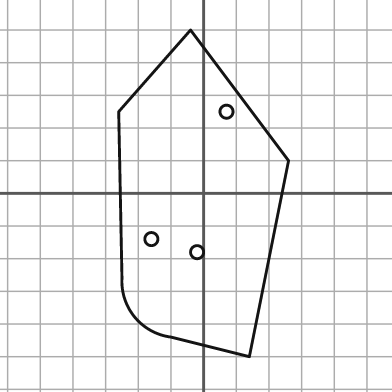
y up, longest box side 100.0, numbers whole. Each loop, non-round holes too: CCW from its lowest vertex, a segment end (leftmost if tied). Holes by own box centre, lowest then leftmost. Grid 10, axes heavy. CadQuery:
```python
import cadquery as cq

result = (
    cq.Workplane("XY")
    .moveTo(14.0, -50.0)
    .lineTo(26.0, 10.0)
    .lineTo(-4.0, 50.0)
    .lineTo(-26.0, 25.0)
    .lineTo(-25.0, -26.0)
    .threePointArc((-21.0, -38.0), (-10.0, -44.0))
    .close()
    .moveTo(-2.0, -18.0)
    .circle(2.0)
    .moveTo(-16.0, -14.0)
    .circle(2.0)
    .moveTo(7.0, 25.0)
    .circle(2.0)
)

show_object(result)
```